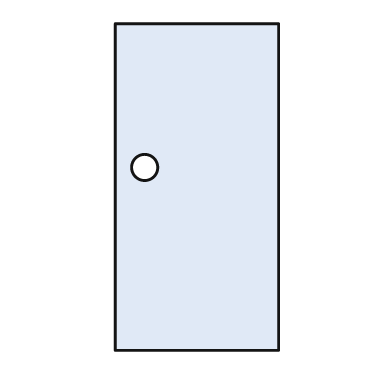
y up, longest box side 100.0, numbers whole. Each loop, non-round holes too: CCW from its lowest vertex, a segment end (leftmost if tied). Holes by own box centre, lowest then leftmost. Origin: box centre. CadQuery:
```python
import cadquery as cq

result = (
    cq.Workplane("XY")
    .moveTo(-25.0, -50.0)
    .lineTo(25.0, -50.0)
    .lineTo(25.0, 50.0)
    .lineTo(-25.0, 50.0)
    .close()
    .moveTo(-16.0, 6.0)
    .circle(4.0)
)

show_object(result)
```